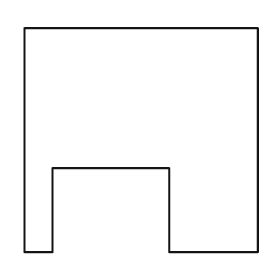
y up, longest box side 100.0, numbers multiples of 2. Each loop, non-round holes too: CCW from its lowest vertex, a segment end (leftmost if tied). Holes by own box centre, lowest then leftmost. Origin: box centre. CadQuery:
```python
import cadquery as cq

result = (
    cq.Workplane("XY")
    .moveTo(-50.0, -48.0)
    .lineTo(-38.0, -48.0)
    .lineTo(-38.0, -12.0)
    .lineTo(12.0, -12.0)
    .lineTo(12.0, -48.0)
    .lineTo(50.0, -48.0)
    .lineTo(50.0, 48.0)
    .lineTo(-50.0, 48.0)
    .close()
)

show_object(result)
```